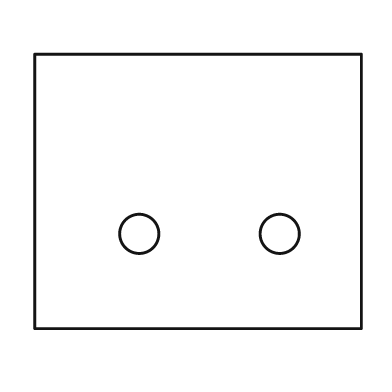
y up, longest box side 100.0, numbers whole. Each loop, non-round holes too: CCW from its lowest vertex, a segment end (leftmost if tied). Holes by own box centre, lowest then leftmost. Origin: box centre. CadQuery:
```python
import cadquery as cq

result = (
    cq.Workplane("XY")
    .moveTo(-50.0, -42.0)
    .lineTo(50.0, -42.0)
    .lineTo(50.0, 42.0)
    .lineTo(-50.0, 42.0)
    .close()
    .moveTo(-18.0, -13.0)
    .circle(6.0)
    .moveTo(25.0, -13.0)
    .circle(6.0)
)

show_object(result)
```